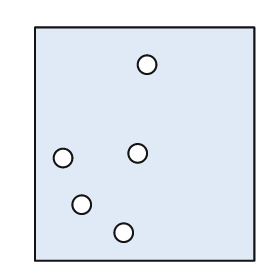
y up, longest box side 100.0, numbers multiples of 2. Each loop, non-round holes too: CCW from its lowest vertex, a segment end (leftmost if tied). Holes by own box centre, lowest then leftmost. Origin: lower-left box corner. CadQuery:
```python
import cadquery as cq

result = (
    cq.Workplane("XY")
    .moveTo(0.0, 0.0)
    .lineTo(94.0, 0.0)
    .lineTo(94.0, 100.0)
    .lineTo(0.0, 100.0)
    .close()
    .moveTo(38.0, 12.0)
    .circle(4.0)
    .moveTo(20.0, 24.0)
    .circle(4.0)
    .moveTo(12.0, 44.0)
    .circle(4.0)
    .moveTo(44.0, 46.0)
    .circle(4.0)
    .moveTo(48.0, 84.0)
    .circle(4.0)
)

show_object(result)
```